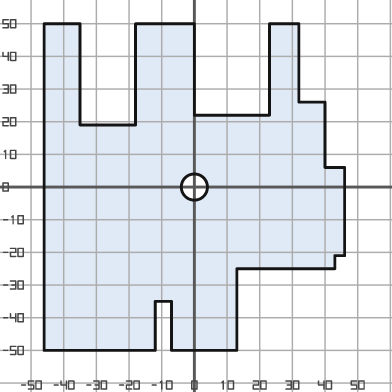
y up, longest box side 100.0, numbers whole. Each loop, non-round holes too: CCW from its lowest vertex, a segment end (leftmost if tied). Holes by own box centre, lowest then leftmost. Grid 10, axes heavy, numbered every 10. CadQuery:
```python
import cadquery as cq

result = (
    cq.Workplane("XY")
    .moveTo(-46.0, -50.0)
    .lineTo(-12.0, -50.0)
    .lineTo(-12.0, -35.0)
    .lineTo(-7.0, -35.0)
    .lineTo(-7.0, -50.0)
    .lineTo(13.0, -50.0)
    .lineTo(13.0, -25.0)
    .lineTo(43.0, -25.0)
    .lineTo(43.0, -21.0)
    .lineTo(46.0, -21.0)
    .lineTo(46.0, 6.0)
    .lineTo(40.0, 6.0)
    .lineTo(40.0, 26.0)
    .lineTo(32.0, 26.0)
    .lineTo(32.0, 50.0)
    .lineTo(23.0, 50.0)
    .lineTo(23.0, 22.0)
    .lineTo(0.0, 22.0)
    .lineTo(0.0, 50.0)
    .lineTo(-18.0, 50.0)
    .lineTo(-18.0, 19.0)
    .lineTo(-35.0, 19.0)
    .lineTo(-35.0, 50.0)
    .lineTo(-46.0, 50.0)
    .close()
    .moveTo(0.0, 0.0)
    .circle(4.0)
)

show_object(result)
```